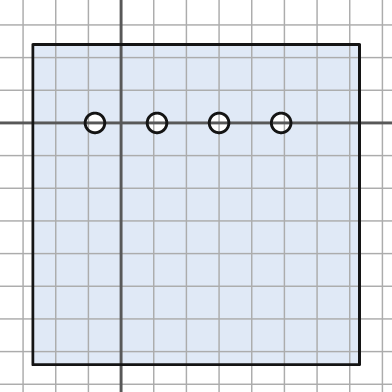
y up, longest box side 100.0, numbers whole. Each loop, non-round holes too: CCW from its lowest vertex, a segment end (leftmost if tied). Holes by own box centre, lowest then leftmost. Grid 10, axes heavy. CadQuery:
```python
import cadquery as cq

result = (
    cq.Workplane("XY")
    .moveTo(-27.0, -74.0)
    .lineTo(73.0, -74.0)
    .lineTo(73.0, 24.0)
    .lineTo(-27.0, 24.0)
    .close()
    .moveTo(-8.0, 0.0)
    .circle(3.0)
    .moveTo(11.0, 0.0)
    .circle(3.0)
    .moveTo(30.0, 0.0)
    .circle(3.0)
    .moveTo(49.0, 0.0)
    .circle(3.0)
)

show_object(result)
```